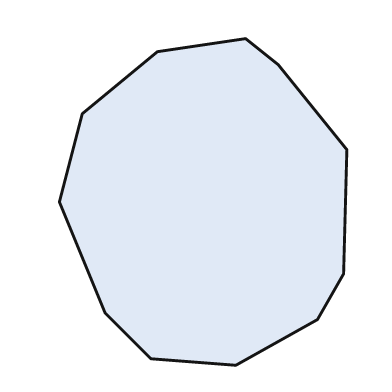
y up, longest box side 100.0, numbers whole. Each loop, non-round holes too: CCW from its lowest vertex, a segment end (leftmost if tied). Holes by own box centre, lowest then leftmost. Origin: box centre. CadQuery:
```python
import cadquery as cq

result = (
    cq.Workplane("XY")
    .moveTo(10.0, -50.0)
    .lineTo(35.0, -36.0)
    .lineTo(43.0, -22.0)
    .lineTo(44.0, 16.0)
    .lineTo(23.0, 42.0)
    .lineTo(13.0, 50.0)
    .lineTo(-14.0, 46.0)
    .lineTo(-37.0, 27.0)
    .lineTo(-44.0, 0.0)
    .lineTo(-30.0, -34.0)
    .lineTo(-16.0, -48.0)
    .close()
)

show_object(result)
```